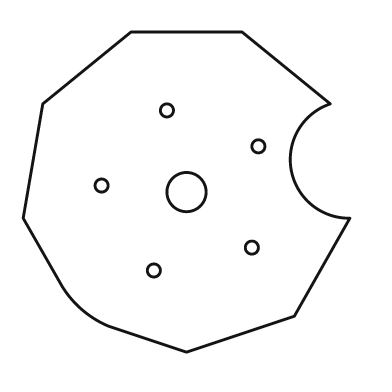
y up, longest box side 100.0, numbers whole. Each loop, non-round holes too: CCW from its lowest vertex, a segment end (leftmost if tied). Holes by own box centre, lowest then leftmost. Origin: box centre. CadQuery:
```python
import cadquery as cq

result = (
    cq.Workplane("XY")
    .moveTo(0.0, -49.0)
    .lineTo(33.0, -38.0)
    .lineTo(50.0, -8.0)
    .threePointArc((32.0, 7.0), (44.0, 27.0))
    .lineTo(17.0, 49.0)
    .lineTo(-17.0, 49.0)
    .lineTo(-44.0, 27.0)
    .lineTo(-50.0, -8.0)
    .lineTo(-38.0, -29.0)
    .threePointArc((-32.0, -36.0), (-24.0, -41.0))
    .close()
    .moveTo(-10.0, -24.0)
    .circle(2.0)
    .moveTo(20.0, -17.0)
    .circle(2.0)
    .moveTo(0.0, 0.0)
    .circle(6.0)
    .moveTo(-26.0, 2.0)
    .circle(2.0)
    .moveTo(22.0, 14.0)
    .circle(2.0)
    .moveTo(-6.0, 25.0)
    .circle(2.0)
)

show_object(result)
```